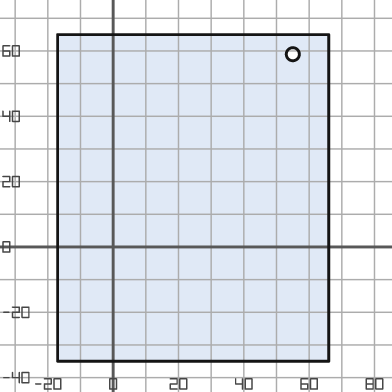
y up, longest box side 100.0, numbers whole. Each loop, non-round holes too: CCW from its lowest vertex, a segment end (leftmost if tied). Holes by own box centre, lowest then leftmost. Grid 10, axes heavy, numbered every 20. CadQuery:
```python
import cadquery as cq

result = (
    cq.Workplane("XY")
    .moveTo(-17.0, -35.0)
    .lineTo(66.0, -35.0)
    .lineTo(66.0, 65.0)
    .lineTo(-17.0, 65.0)
    .close()
    .moveTo(55.0, 59.0)
    .circle(2.0)
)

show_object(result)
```